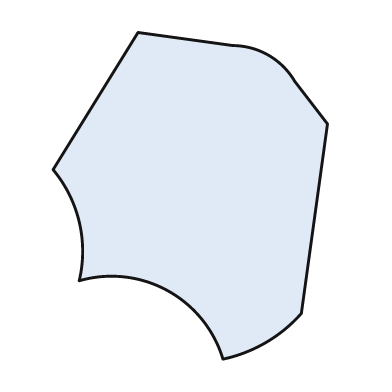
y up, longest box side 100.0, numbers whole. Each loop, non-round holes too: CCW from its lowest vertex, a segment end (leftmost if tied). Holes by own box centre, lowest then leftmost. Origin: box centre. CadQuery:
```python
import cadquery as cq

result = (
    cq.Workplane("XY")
    .moveTo(10.0, -50.0)
    .threePointArc((23.0, -45.0), (34.0, -36.0))
    .lineTo(42.0, 22.0)
    .lineTo(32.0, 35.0)
    .threePointArc((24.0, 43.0), (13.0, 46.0))
    .lineTo(-16.0, 50.0)
    .lineTo(-42.0, 8.0)
    .threePointArc((-34.0, -8.0), (-34.0, -26.0))
    .threePointArc((-7.0, -29.0), (10.0, -50.0))
    .close()
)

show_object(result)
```